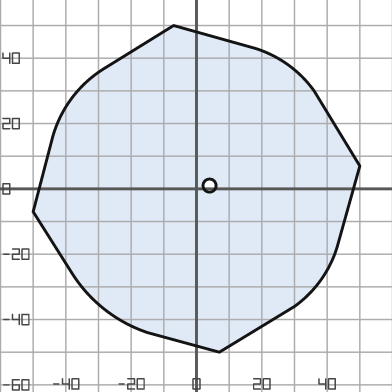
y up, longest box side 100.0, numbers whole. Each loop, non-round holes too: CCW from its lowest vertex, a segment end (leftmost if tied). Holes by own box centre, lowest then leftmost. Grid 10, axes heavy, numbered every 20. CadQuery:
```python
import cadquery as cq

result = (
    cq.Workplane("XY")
    .moveTo(7.0, -50.0)
    .lineTo(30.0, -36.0)
    .threePointArc((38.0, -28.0), (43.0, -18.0))
    .lineTo(50.0, 7.0)
    .lineTo(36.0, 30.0)
    .threePointArc((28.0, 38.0), (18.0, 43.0))
    .lineTo(-7.0, 50.0)
    .lineTo(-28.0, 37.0)
    .threePointArc((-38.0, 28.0), (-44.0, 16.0))
    .lineTo(-50.0, -7.0)
    .lineTo(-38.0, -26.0)
    .threePointArc((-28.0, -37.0), (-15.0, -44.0))
    .close()
    .moveTo(4.0, 1.0)
    .circle(2.0)
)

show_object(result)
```